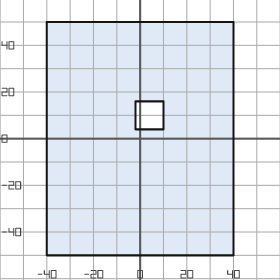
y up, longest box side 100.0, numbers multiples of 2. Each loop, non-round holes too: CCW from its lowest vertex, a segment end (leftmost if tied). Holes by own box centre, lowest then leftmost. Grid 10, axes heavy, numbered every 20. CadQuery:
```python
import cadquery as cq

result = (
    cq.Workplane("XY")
    .moveTo(-40.0, -50.0)
    .lineTo(40.0, -50.0)
    .lineTo(40.0, 50.0)
    .lineTo(-40.0, 50.0)
    .close()
    .moveTo(-2.0, 4.0)
    .lineTo(10.0, 4.0)
    .lineTo(10.0, 16.0)
    .lineTo(-2.0, 16.0)
    .close()
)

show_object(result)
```